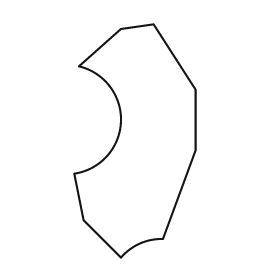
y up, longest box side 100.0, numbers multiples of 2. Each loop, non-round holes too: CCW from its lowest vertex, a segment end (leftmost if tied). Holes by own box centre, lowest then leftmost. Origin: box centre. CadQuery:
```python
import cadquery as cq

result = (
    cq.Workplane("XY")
    .moveTo(-6.0, -50.0)
    .threePointArc((2.0, -44.0), (12.0, -42.0))
    .lineTo(26.0, -4.0)
    .lineTo(26.0, 22.0)
    .lineTo(8.0, 50.0)
    .lineTo(-6.0, 48.0)
    .lineTo(-24.0, 32.0)
    .threePointArc((-6.0, 8.0), (-26.0, -14.0))
    .lineTo(-22.0, -34.0)
    .close()
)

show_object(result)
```